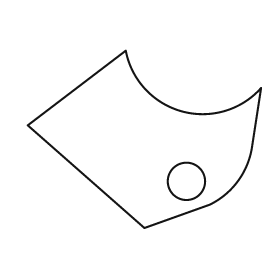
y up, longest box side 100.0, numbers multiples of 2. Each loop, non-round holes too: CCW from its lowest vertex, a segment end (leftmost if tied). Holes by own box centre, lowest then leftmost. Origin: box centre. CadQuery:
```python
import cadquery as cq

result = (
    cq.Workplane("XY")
    .moveTo(0.0, -38.0)
    .lineTo(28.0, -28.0)
    .threePointArc((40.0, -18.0), (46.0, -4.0))
    .lineTo(50.0, 22.0)
    .threePointArc((16.0, 12.0), (-8.0, 38.0))
    .lineTo(-50.0, 6.0)
    .close()
    .moveTo(18.0, -18.0)
    .circle(8.0)
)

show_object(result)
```